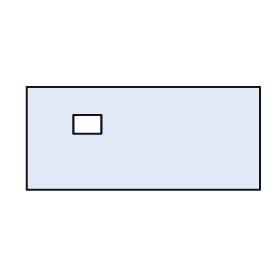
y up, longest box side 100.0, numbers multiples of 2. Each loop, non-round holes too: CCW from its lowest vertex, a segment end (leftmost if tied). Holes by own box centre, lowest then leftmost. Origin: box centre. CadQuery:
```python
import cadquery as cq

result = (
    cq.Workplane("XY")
    .moveTo(-50.0, -22.0)
    .lineTo(50.0, -22.0)
    .lineTo(50.0, 22.0)
    .lineTo(-50.0, 22.0)
    .close()
    .moveTo(-30.0, 2.0)
    .lineTo(-18.0, 2.0)
    .lineTo(-18.0, 10.0)
    .lineTo(-30.0, 10.0)
    .close()
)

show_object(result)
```